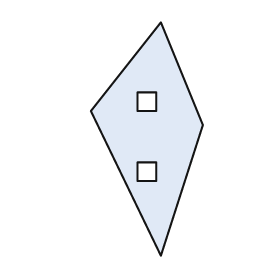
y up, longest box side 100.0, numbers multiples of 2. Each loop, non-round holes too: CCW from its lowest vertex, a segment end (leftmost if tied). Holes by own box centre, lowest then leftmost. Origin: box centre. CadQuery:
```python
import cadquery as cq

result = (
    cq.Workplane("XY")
    .moveTo(6.0, -50.0)
    .lineTo(24.0, 6.0)
    .lineTo(6.0, 50.0)
    .lineTo(-24.0, 12.0)
    .close()
    .moveTo(-4.0, -18.0)
    .lineTo(4.0, -18.0)
    .lineTo(4.0, -10.0)
    .lineTo(-4.0, -10.0)
    .close()
    .moveTo(-4.0, 12.0)
    .lineTo(4.0, 12.0)
    .lineTo(4.0, 20.0)
    .lineTo(-4.0, 20.0)
    .close()
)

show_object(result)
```